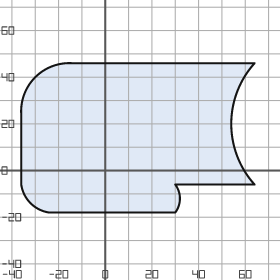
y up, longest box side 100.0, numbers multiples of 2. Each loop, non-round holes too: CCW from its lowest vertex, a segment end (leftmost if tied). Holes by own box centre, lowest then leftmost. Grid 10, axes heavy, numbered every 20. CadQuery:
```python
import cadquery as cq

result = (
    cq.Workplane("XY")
    .moveTo(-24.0, -18.0)
    .lineTo(30.0, -18.0)
    .threePointArc((32.0, -12.0), (30.0, -6.0))
    .lineTo(64.0, -6.0)
    .threePointArc((54.0, 20.0), (64.0, 46.0))
    .lineTo(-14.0, 46.0)
    .threePointArc((-30.0, 40.0), (-36.0, 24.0))
    .lineTo(-36.0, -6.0)
    .threePointArc((-32.0, -14.0), (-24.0, -18.0))
    .close()
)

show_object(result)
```